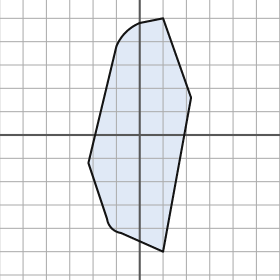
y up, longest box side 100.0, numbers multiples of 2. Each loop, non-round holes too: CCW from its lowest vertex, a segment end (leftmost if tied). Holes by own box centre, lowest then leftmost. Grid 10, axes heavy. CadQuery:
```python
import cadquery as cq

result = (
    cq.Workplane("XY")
    .moveTo(10.0, -50.0)
    .lineTo(22.0, 16.0)
    .lineTo(10.0, 50.0)
    .lineTo(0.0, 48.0)
    .threePointArc((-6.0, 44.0), (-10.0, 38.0))
    .lineTo(-22.0, -12.0)
    .lineTo(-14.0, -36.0)
    .threePointArc((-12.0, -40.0), (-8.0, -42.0))
    .close()
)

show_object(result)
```